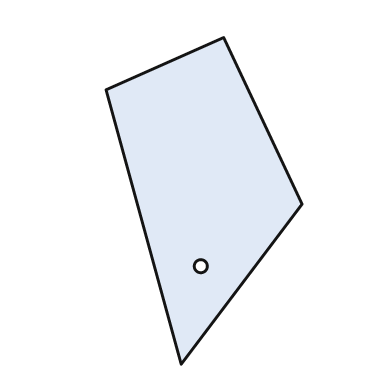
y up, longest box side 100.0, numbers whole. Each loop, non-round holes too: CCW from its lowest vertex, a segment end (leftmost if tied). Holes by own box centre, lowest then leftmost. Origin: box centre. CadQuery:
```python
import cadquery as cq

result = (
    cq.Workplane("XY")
    .moveTo(-7.0, -50.0)
    .lineTo(30.0, -1.0)
    .lineTo(6.0, 50.0)
    .lineTo(-30.0, 34.0)
    .close()
    .moveTo(-1.0, -20.0)
    .circle(2.0)
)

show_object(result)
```